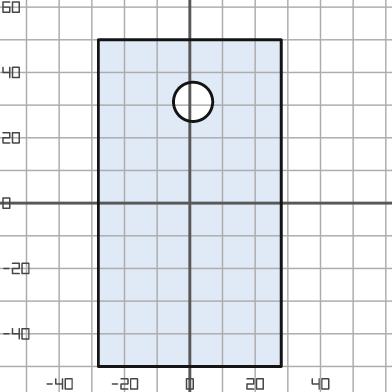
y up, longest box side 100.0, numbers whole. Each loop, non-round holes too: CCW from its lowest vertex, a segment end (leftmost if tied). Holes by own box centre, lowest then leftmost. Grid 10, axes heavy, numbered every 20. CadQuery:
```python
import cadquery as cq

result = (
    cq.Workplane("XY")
    .moveTo(-28.0, -50.0)
    .lineTo(28.0, -50.0)
    .lineTo(28.0, 50.0)
    .lineTo(-28.0, 50.0)
    .close()
    .moveTo(1.0, 31.0)
    .circle(6.0)
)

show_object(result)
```